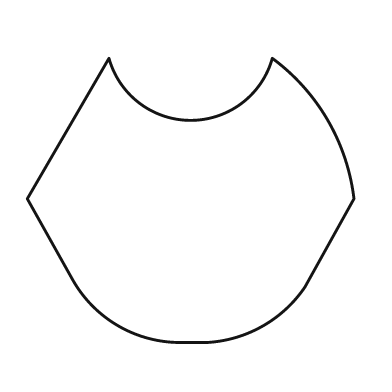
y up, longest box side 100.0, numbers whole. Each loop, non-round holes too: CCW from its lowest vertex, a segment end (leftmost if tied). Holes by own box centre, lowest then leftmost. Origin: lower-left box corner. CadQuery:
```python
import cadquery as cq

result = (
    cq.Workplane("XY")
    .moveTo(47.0, 0.0)
    .lineTo(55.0, 0.0)
    .threePointArc((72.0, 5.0), (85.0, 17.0))
    .lineTo(100.0, 44.0)
    .threePointArc((92.0, 68.0), (75.0, 87.0))
    .threePointArc((50.0, 68.0), (25.0, 87.0))
    .lineTo(0.0, 44.0)
    .lineTo(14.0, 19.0)
    .threePointArc((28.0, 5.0), (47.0, 0.0))
    .close()
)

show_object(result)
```